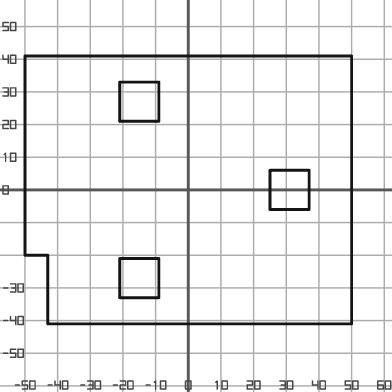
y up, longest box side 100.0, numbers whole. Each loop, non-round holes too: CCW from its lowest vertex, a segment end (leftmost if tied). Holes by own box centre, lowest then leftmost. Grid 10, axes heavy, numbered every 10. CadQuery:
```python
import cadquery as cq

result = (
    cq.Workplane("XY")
    .moveTo(-43.0, -41.0)
    .lineTo(50.0, -41.0)
    .lineTo(50.0, 41.0)
    .lineTo(-50.0, 41.0)
    .lineTo(-50.0, -20.0)
    .lineTo(-43.0, -20.0)
    .close()
    .moveTo(-21.0, -33.0)
    .lineTo(-9.0, -33.0)
    .lineTo(-9.0, -21.0)
    .lineTo(-21.0, -21.0)
    .close()
    .moveTo(25.0, -6.0)
    .lineTo(37.0, -6.0)
    .lineTo(37.0, 6.0)
    .lineTo(25.0, 6.0)
    .close()
    .moveTo(-21.0, 21.0)
    .lineTo(-9.0, 21.0)
    .lineTo(-9.0, 33.0)
    .lineTo(-21.0, 33.0)
    .close()
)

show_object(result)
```